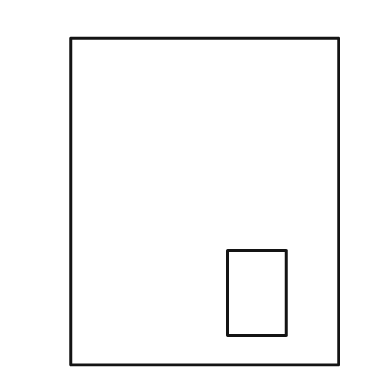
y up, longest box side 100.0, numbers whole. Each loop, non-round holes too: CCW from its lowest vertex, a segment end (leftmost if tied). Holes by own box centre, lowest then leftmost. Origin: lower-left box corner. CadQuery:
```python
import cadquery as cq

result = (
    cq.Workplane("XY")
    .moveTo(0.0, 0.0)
    .lineTo(82.0, 0.0)
    .lineTo(82.0, 100.0)
    .lineTo(0.0, 100.0)
    .close()
    .moveTo(48.0, 9.0)
    .lineTo(66.0, 9.0)
    .lineTo(66.0, 35.0)
    .lineTo(48.0, 35.0)
    .close()
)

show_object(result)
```